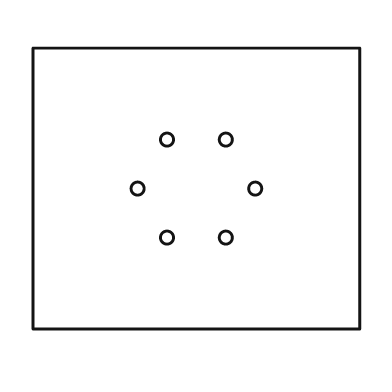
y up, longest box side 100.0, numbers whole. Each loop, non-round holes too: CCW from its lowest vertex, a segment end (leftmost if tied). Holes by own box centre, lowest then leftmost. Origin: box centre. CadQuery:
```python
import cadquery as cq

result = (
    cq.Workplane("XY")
    .moveTo(-50.0, -43.0)
    .lineTo(50.0, -43.0)
    .lineTo(50.0, 43.0)
    .lineTo(-50.0, 43.0)
    .close()
    .moveTo(-9.0, -15.0)
    .circle(2.0)
    .moveTo(9.0, -15.0)
    .circle(2.0)
    .moveTo(-18.0, 0.0)
    .circle(2.0)
    .moveTo(18.0, 0.0)
    .circle(2.0)
    .moveTo(-9.0, 15.0)
    .circle(2.0)
    .moveTo(9.0, 15.0)
    .circle(2.0)
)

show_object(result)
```